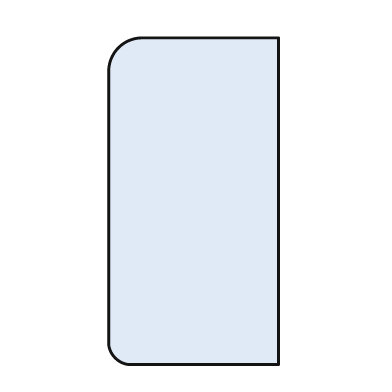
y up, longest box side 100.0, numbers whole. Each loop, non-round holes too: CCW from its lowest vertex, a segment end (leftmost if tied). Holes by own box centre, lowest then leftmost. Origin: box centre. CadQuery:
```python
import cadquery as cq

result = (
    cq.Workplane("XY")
    .moveTo(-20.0, -50.0)
    .lineTo(26.0, -50.0)
    .lineTo(26.0, 50.0)
    .lineTo(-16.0, 50.0)
    .threePointArc((-23.0, 47.0), (-26.0, 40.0))
    .lineTo(-26.0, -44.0)
    .threePointArc((-24.0, -48.0), (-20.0, -50.0))
    .close()
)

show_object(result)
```